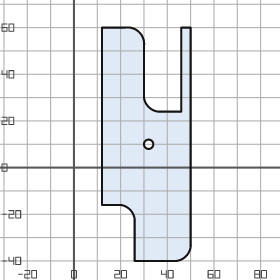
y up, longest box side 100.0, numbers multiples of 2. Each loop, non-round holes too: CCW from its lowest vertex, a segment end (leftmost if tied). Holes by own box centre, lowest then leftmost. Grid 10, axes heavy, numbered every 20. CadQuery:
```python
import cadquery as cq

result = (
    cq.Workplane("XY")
    .moveTo(26.0, -40.0)
    .lineTo(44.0, -40.0)
    .threePointArc((48.0, -38.0), (50.0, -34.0))
    .lineTo(50.0, 60.0)
    .lineTo(46.0, 60.0)
    .lineTo(46.0, 24.0)
    .lineTo(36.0, 24.0)
    .threePointArc((32.0, 26.0), (30.0, 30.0))
    .lineTo(30.0, 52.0)
    .threePointArc((28.0, 58.0), (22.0, 60.0))
    .lineTo(12.0, 60.0)
    .lineTo(12.0, -16.0)
    .lineTo(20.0, -16.0)
    .threePointArc((24.0, -18.0), (26.0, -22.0))
    .close()
    .moveTo(32.0, 10.0)
    .circle(2.0)
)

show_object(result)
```